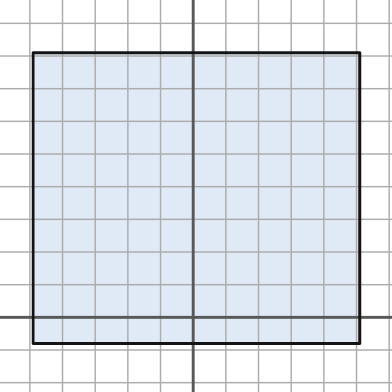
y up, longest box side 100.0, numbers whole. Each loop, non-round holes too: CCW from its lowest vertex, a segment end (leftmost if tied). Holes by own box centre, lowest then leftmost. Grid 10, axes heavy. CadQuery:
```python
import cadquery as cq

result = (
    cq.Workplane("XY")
    .moveTo(-49.0, -8.0)
    .lineTo(51.0, -8.0)
    .lineTo(51.0, 81.0)
    .lineTo(-49.0, 81.0)
    .close()
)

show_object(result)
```